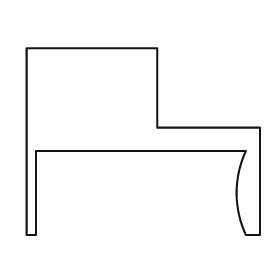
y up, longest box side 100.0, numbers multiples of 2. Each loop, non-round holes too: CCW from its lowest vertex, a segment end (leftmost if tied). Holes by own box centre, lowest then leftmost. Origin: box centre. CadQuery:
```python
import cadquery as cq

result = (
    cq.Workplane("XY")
    .moveTo(-50.0, -40.0)
    .lineTo(-46.0, -40.0)
    .lineTo(-46.0, -4.0)
    .lineTo(44.0, -4.0)
    .threePointArc((40.0, -22.0), (44.0, -40.0))
    .lineTo(50.0, -40.0)
    .lineTo(50.0, 6.0)
    .lineTo(6.0, 6.0)
    .lineTo(6.0, 40.0)
    .lineTo(-50.0, 40.0)
    .close()
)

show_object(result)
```